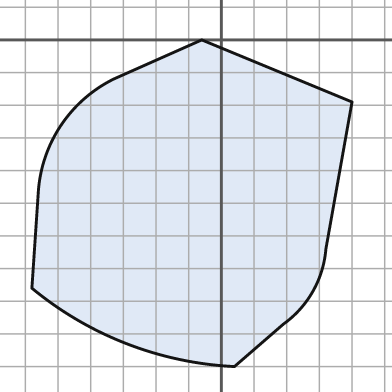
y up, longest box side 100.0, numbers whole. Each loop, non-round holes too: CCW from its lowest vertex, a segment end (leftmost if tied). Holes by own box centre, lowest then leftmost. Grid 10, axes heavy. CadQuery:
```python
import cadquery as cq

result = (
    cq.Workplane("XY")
    .moveTo(4.0, -100.0)
    .lineTo(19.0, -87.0)
    .threePointArc((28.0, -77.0), (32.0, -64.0))
    .lineTo(40.0, -19.0)
    .lineTo(-6.0, 0.0)
    .lineTo(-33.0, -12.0)
    .threePointArc((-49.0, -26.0), (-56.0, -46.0))
    .lineTo(-58.0, -76.0)
    .threePointArc((-29.0, -93.0), (4.0, -100.0))
    .close()
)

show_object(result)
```